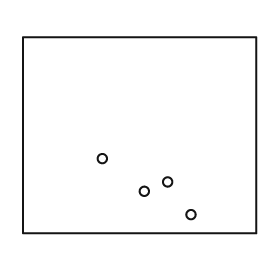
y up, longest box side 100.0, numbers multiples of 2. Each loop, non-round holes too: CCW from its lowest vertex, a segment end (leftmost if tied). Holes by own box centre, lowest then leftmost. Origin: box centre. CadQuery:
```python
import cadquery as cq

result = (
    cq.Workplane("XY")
    .moveTo(-50.0, -42.0)
    .lineTo(50.0, -42.0)
    .lineTo(50.0, 42.0)
    .lineTo(-50.0, 42.0)
    .close()
    .moveTo(22.0, -34.0)
    .circle(2.0)
    .moveTo(2.0, -24.0)
    .circle(2.0)
    .moveTo(12.0, -20.0)
    .circle(2.0)
    .moveTo(-16.0, -10.0)
    .circle(2.0)
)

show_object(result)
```